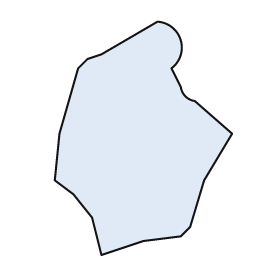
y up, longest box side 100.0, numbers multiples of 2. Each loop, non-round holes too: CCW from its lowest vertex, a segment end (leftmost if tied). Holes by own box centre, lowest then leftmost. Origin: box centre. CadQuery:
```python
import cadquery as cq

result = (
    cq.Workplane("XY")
    .moveTo(-18.0, -50.0)
    .lineTo(0.0, -44.0)
    .lineTo(16.0, -42.0)
    .lineTo(20.0, -38.0)
    .lineTo(26.0, -18.0)
    .lineTo(38.0, 2.0)
    .lineTo(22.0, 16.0)
    .threePointArc((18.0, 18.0), (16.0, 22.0))
    .lineTo(12.0, 30.0)
    .threePointArc((16.0, 42.0), (6.0, 50.0))
    .lineTo(-18.0, 36.0)
    .lineTo(-24.0, 34.0)
    .lineTo(-28.0, 30.0)
    .lineTo(-36.0, 2.0)
    .lineTo(-38.0, -18.0)
    .lineTo(-30.0, -24.0)
    .lineTo(-22.0, -34.0)
    .close()
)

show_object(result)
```